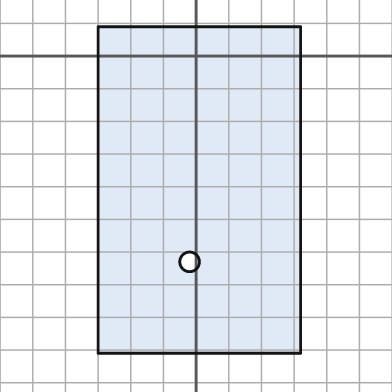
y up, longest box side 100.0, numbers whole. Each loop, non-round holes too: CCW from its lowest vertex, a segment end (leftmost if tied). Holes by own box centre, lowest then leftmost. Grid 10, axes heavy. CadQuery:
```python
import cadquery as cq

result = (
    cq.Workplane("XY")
    .moveTo(-30.0, -91.0)
    .lineTo(32.0, -91.0)
    .lineTo(32.0, 9.0)
    .lineTo(-30.0, 9.0)
    .close()
    .moveTo(-2.0, -63.0)
    .circle(3.0)
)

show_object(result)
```